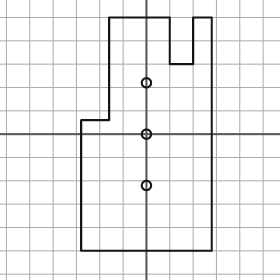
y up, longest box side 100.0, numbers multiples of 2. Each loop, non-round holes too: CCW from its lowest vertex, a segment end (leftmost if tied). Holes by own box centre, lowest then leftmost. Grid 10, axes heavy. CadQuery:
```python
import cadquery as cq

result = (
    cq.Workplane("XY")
    .moveTo(-28.0, -50.0)
    .lineTo(28.0, -50.0)
    .lineTo(28.0, 50.0)
    .lineTo(20.0, 50.0)
    .lineTo(20.0, 30.0)
    .lineTo(10.0, 30.0)
    .lineTo(10.0, 50.0)
    .lineTo(-16.0, 50.0)
    .lineTo(-16.0, 6.0)
    .lineTo(-28.0, 6.0)
    .close()
    .moveTo(0.0, -22.0)
    .circle(2.0)
    .moveTo(0.0, 0.0)
    .circle(2.0)
    .moveTo(0.0, 22.0)
    .circle(2.0)
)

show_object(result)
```